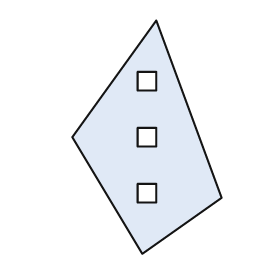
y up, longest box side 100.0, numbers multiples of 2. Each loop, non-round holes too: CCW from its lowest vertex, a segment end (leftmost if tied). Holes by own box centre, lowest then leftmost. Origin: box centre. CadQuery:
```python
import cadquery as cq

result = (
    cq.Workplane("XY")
    .moveTo(-2.0, -50.0)
    .lineTo(32.0, -26.0)
    .lineTo(4.0, 50.0)
    .lineTo(-32.0, 0.0)
    .close()
    .moveTo(-4.0, -28.0)
    .lineTo(4.0, -28.0)
    .lineTo(4.0, -20.0)
    .lineTo(-4.0, -20.0)
    .close()
    .moveTo(-4.0, -4.0)
    .lineTo(4.0, -4.0)
    .lineTo(4.0, 4.0)
    .lineTo(-4.0, 4.0)
    .close()
    .moveTo(-4.0, 20.0)
    .lineTo(4.0, 20.0)
    .lineTo(4.0, 28.0)
    .lineTo(-4.0, 28.0)
    .close()
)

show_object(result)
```